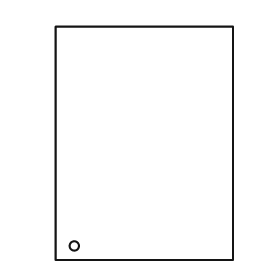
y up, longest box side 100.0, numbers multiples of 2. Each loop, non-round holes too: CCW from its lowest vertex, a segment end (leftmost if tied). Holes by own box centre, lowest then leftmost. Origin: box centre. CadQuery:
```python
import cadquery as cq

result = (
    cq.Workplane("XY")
    .moveTo(-38.0, -50.0)
    .lineTo(38.0, -50.0)
    .lineTo(38.0, 50.0)
    .lineTo(-38.0, 50.0)
    .close()
    .moveTo(-30.0, -44.0)
    .circle(2.0)
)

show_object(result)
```